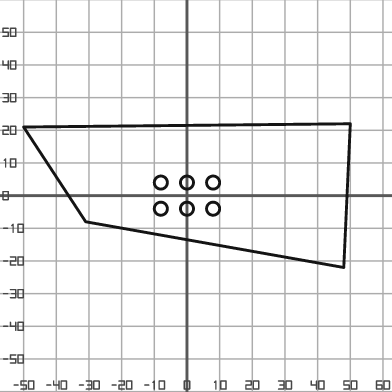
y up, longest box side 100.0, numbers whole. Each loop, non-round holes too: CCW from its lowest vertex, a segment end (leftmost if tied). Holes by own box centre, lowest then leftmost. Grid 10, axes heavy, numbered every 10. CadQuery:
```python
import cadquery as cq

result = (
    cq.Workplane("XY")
    .moveTo(48.0, -22.0)
    .lineTo(50.0, 22.0)
    .lineTo(-50.0, 21.0)
    .lineTo(-31.0, -8.0)
    .close()
    .moveTo(-8.0, -4.0)
    .circle(2.0)
    .moveTo(0.0, -4.0)
    .circle(2.0)
    .moveTo(8.0, -4.0)
    .circle(2.0)
    .moveTo(-8.0, 4.0)
    .circle(2.0)
    .moveTo(0.0, 4.0)
    .circle(2.0)
    .moveTo(8.0, 4.0)
    .circle(2.0)
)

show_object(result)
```